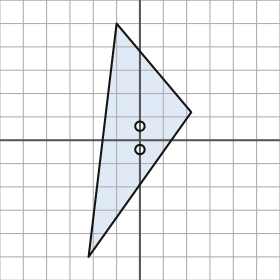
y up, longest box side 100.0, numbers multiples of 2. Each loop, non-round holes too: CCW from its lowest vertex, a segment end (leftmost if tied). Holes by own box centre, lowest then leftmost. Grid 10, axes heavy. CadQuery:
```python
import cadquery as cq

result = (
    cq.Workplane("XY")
    .moveTo(-22.0, -50.0)
    .lineTo(22.0, 12.0)
    .lineTo(-10.0, 50.0)
    .close()
    .moveTo(0.0, -4.0)
    .circle(2.0)
    .moveTo(0.0, 6.0)
    .circle(2.0)
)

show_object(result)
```